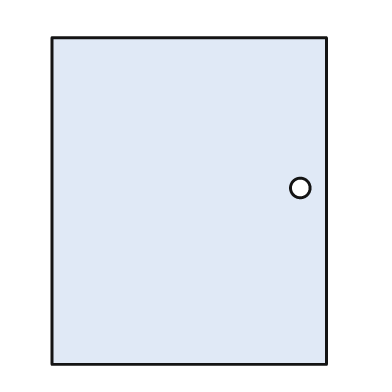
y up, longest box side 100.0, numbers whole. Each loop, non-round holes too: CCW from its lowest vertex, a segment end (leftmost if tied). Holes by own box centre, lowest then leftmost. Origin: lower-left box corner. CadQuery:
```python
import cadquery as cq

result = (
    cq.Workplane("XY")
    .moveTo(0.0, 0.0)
    .lineTo(84.0, 0.0)
    .lineTo(84.0, 100.0)
    .lineTo(0.0, 100.0)
    .close()
    .moveTo(76.0, 54.0)
    .circle(3.0)
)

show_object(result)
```